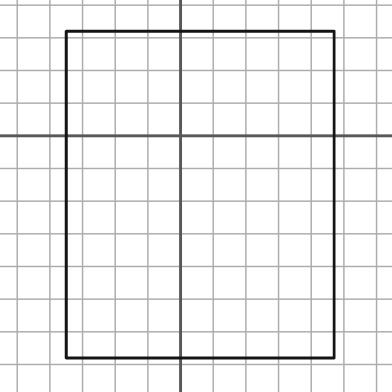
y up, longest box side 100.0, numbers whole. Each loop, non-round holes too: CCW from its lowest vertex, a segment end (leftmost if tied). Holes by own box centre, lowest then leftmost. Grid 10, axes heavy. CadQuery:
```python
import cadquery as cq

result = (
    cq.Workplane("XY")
    .moveTo(-35.0, -68.0)
    .lineTo(47.0, -68.0)
    .lineTo(47.0, 32.0)
    .lineTo(-35.0, 32.0)
    .close()
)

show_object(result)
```